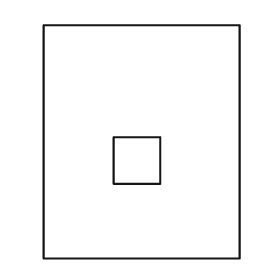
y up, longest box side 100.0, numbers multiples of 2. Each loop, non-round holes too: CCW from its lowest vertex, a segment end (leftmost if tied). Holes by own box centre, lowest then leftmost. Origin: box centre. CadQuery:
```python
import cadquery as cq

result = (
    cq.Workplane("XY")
    .moveTo(-42.0, -50.0)
    .lineTo(42.0, -50.0)
    .lineTo(42.0, 50.0)
    .lineTo(-42.0, 50.0)
    .close()
    .moveTo(-12.0, -18.0)
    .lineTo(8.0, -18.0)
    .lineTo(8.0, 2.0)
    .lineTo(-12.0, 2.0)
    .close()
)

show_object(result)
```